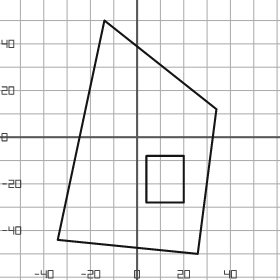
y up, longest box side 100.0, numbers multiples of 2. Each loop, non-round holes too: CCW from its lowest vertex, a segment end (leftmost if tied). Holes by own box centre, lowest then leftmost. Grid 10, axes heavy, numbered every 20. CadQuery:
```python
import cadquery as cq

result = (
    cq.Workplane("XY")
    .moveTo(26.0, -50.0)
    .lineTo(34.0, 12.0)
    .lineTo(-14.0, 50.0)
    .lineTo(-34.0, -44.0)
    .close()
    .moveTo(4.0, -28.0)
    .lineTo(20.0, -28.0)
    .lineTo(20.0, -8.0)
    .lineTo(4.0, -8.0)
    .close()
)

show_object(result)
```